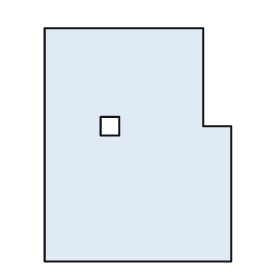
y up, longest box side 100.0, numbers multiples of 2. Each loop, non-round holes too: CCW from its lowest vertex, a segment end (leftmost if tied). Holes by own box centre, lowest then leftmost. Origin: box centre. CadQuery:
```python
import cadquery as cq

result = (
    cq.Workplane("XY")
    .moveTo(-40.0, -50.0)
    .lineTo(40.0, -50.0)
    .lineTo(40.0, 8.0)
    .lineTo(28.0, 8.0)
    .lineTo(28.0, 50.0)
    .lineTo(-40.0, 50.0)
    .close()
    .moveTo(-16.0, 4.0)
    .lineTo(-8.0, 4.0)
    .lineTo(-8.0, 12.0)
    .lineTo(-16.0, 12.0)
    .close()
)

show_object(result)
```